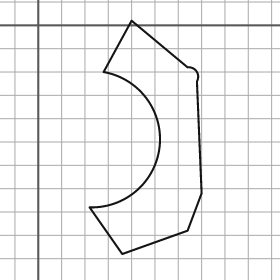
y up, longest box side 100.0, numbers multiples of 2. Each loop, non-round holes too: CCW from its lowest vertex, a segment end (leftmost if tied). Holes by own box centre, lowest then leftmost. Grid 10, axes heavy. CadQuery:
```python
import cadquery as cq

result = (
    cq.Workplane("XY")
    .moveTo(36.0, -98.0)
    .lineTo(64.0, -88.0)
    .lineTo(70.0, -72.0)
    .lineTo(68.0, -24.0)
    .threePointArc((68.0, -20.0), (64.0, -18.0))
    .lineTo(40.0, 2.0)
    .lineTo(28.0, -20.0)
    .threePointArc((52.0, -52.0), (22.0, -78.0))
    .close()
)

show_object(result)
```